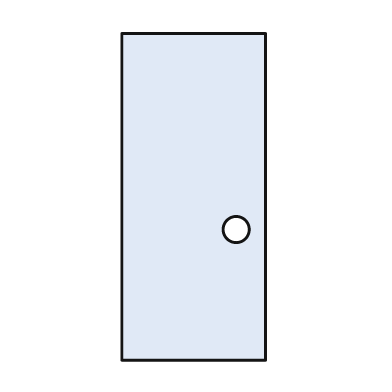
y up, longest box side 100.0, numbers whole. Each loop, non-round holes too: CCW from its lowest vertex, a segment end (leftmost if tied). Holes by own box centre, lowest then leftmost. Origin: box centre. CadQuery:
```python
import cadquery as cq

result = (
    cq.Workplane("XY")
    .moveTo(-22.0, -50.0)
    .lineTo(22.0, -50.0)
    .lineTo(22.0, 50.0)
    .lineTo(-22.0, 50.0)
    .close()
    .moveTo(13.0, -10.0)
    .circle(4.0)
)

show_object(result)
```